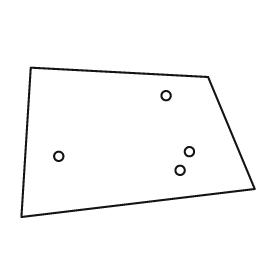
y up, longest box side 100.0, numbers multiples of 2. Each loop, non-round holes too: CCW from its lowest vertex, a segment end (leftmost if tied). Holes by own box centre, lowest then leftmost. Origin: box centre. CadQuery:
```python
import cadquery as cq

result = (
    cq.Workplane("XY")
    .moveTo(-50.0, -32.0)
    .lineTo(50.0, -20.0)
    .lineTo(30.0, 28.0)
    .lineTo(-46.0, 32.0)
    .close()
    .moveTo(18.0, -12.0)
    .circle(2.0)
    .moveTo(-34.0, -6.0)
    .circle(2.0)
    .moveTo(22.0, -4.0)
    .circle(2.0)
    .moveTo(12.0, 20.0)
    .circle(2.0)
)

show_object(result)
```